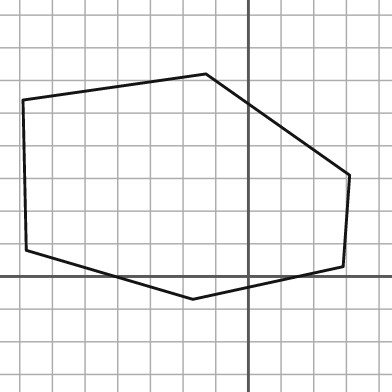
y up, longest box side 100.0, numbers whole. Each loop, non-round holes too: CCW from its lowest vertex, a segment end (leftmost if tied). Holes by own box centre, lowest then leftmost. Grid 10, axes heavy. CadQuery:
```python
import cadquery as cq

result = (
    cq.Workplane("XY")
    .moveTo(-17.0, -7.0)
    .lineTo(29.0, 3.0)
    .lineTo(31.0, 31.0)
    .lineTo(-13.0, 62.0)
    .lineTo(-69.0, 54.0)
    .lineTo(-68.0, 8.0)
    .close()
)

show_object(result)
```